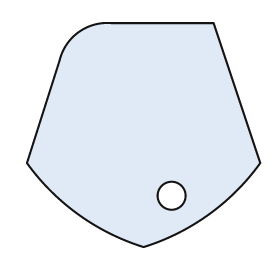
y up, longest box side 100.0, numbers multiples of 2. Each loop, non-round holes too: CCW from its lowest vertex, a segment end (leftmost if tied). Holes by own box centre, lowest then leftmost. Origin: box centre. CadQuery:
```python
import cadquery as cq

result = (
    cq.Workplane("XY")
    .moveTo(0.0, -48.0)
    .threePointArc((28.0, -34.0), (50.0, -12.0))
    .lineTo(30.0, 48.0)
    .lineTo(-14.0, 48.0)
    .threePointArc((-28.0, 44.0), (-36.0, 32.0))
    .lineTo(-50.0, -12.0)
    .threePointArc((-28.0, -34.0), (0.0, -48.0))
    .close()
    .moveTo(12.0, -26.0)
    .circle(6.0)
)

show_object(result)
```